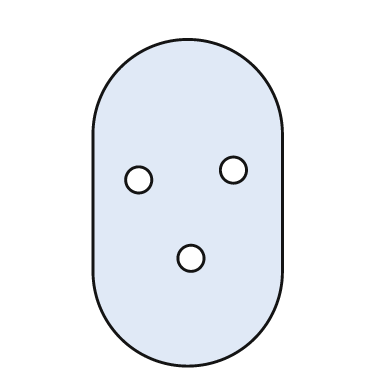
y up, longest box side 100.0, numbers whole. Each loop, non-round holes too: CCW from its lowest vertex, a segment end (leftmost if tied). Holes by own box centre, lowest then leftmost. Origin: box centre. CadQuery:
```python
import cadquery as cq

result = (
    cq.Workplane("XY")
    .moveTo(-29.0, -21.0)
    .threePointArc((0.0, -50.0), (29.0, -21.0))
    .lineTo(29.0, 21.0)
    .threePointArc((0.0, 50.0), (-29.0, 21.0))
    .close()
    .moveTo(1.0, -17.0)
    .circle(4.0)
    .moveTo(-15.0, 7.0)
    .circle(4.0)
    .moveTo(14.0, 10.0)
    .circle(4.0)
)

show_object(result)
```